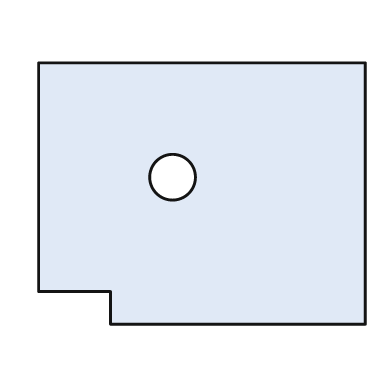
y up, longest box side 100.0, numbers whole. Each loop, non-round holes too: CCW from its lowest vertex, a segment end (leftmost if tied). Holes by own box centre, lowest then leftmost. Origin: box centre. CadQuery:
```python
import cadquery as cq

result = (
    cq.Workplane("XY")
    .moveTo(-28.0, -40.0)
    .lineTo(50.0, -40.0)
    .lineTo(50.0, 40.0)
    .lineTo(-50.0, 40.0)
    .lineTo(-50.0, -30.0)
    .lineTo(-28.0, -30.0)
    .close()
    .moveTo(-9.0, 5.0)
    .circle(7.0)
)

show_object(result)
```